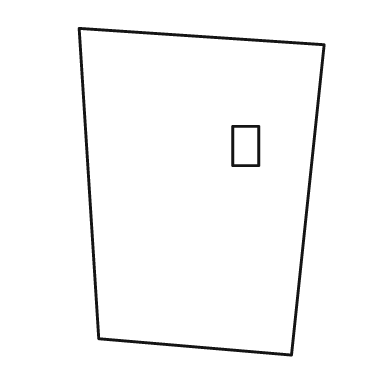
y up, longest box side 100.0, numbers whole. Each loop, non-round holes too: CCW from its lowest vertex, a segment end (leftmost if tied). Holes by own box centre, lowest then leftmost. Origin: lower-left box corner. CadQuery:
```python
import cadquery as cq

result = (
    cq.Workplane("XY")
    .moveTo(65.0, 0.0)
    .lineTo(75.0, 95.0)
    .lineTo(0.0, 100.0)
    .lineTo(6.0, 5.0)
    .close()
    .moveTo(47.0, 58.0)
    .lineTo(55.0, 58.0)
    .lineTo(55.0, 70.0)
    .lineTo(47.0, 70.0)
    .close()
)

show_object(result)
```